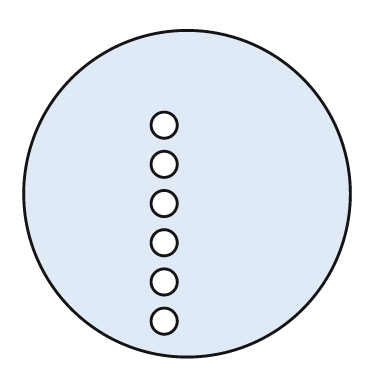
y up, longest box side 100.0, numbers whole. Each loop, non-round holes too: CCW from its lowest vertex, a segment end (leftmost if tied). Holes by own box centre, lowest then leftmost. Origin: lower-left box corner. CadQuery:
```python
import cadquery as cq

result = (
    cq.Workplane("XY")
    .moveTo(50.0, 50.0)
    .circle(50.0)
    .moveTo(43.0, 11.0)
    .circle(4.0)
    .moveTo(43.0, 23.0)
    .circle(4.0)
    .moveTo(43.0, 35.0)
    .circle(4.0)
    .moveTo(43.0, 47.0)
    .circle(4.0)
    .moveTo(43.0, 59.0)
    .circle(4.0)
    .moveTo(43.0, 71.0)
    .circle(4.0)
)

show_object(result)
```